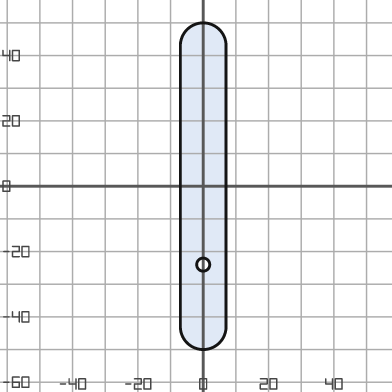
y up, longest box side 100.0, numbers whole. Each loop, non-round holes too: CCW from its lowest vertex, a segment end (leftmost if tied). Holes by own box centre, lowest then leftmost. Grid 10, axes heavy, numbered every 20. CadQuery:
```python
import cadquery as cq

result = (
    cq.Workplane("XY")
    .moveTo(-7.0, -43.0)
    .threePointArc((0.0, -50.0), (7.0, -43.0))
    .lineTo(7.0, 43.0)
    .threePointArc((0.0, 50.0), (-7.0, 43.0))
    .close()
    .moveTo(0.0, -24.0)
    .circle(2.0)
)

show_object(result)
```